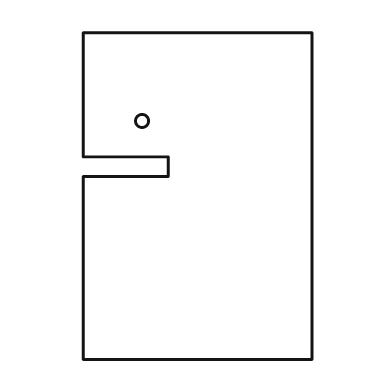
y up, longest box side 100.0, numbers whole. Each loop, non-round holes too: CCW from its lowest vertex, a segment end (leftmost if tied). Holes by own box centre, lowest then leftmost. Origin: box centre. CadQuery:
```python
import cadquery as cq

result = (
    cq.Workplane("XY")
    .moveTo(-35.0, -50.0)
    .lineTo(35.0, -50.0)
    .lineTo(35.0, 50.0)
    .lineTo(-35.0, 50.0)
    .lineTo(-35.0, 12.0)
    .lineTo(-9.0, 12.0)
    .lineTo(-9.0, 6.0)
    .lineTo(-35.0, 6.0)
    .close()
    .moveTo(-17.0, 23.0)
    .circle(2.0)
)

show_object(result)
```